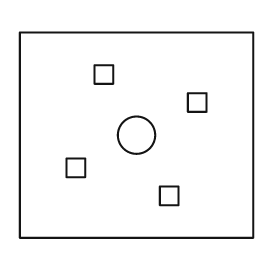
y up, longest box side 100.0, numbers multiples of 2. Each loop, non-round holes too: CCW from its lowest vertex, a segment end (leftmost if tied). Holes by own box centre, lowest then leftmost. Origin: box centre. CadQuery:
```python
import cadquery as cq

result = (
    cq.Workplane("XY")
    .moveTo(-50.0, -44.0)
    .lineTo(50.0, -44.0)
    .lineTo(50.0, 44.0)
    .lineTo(-50.0, 44.0)
    .close()
    .moveTo(10.0, -30.0)
    .lineTo(18.0, -30.0)
    .lineTo(18.0, -22.0)
    .lineTo(10.0, -22.0)
    .close()
    .moveTo(-30.0, -18.0)
    .lineTo(-22.0, -18.0)
    .lineTo(-22.0, -10.0)
    .lineTo(-30.0, -10.0)
    .close()
    .moveTo(0.0, 0.0)
    .circle(8.0)
    .moveTo(22.0, 10.0)
    .lineTo(30.0, 10.0)
    .lineTo(30.0, 18.0)
    .lineTo(22.0, 18.0)
    .close()
    .moveTo(-18.0, 22.0)
    .lineTo(-10.0, 22.0)
    .lineTo(-10.0, 30.0)
    .lineTo(-18.0, 30.0)
    .close()
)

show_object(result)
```